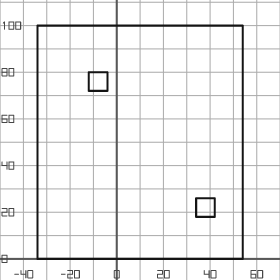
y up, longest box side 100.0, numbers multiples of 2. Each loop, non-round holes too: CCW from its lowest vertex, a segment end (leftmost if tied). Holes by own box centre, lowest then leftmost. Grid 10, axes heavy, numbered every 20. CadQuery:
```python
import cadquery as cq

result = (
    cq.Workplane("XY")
    .moveTo(-34.0, 0.0)
    .lineTo(54.0, 0.0)
    .lineTo(54.0, 100.0)
    .lineTo(-34.0, 100.0)
    .close()
    .moveTo(34.0, 18.0)
    .lineTo(42.0, 18.0)
    .lineTo(42.0, 26.0)
    .lineTo(34.0, 26.0)
    .close()
    .moveTo(-12.0, 72.0)
    .lineTo(-4.0, 72.0)
    .lineTo(-4.0, 80.0)
    .lineTo(-12.0, 80.0)
    .close()
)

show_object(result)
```